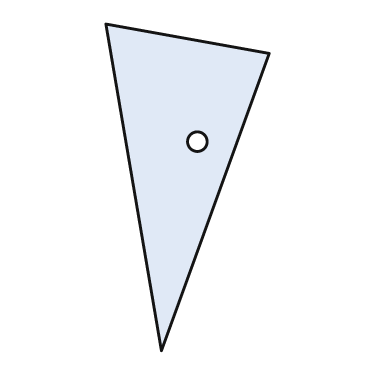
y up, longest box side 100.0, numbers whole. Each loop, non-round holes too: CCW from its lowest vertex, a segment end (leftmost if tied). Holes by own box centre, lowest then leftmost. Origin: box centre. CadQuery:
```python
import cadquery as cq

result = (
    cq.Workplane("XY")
    .moveTo(-8.0, -50.0)
    .lineTo(25.0, 41.0)
    .lineTo(-25.0, 50.0)
    .close()
    .moveTo(3.0, 14.0)
    .circle(3.0)
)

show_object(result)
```